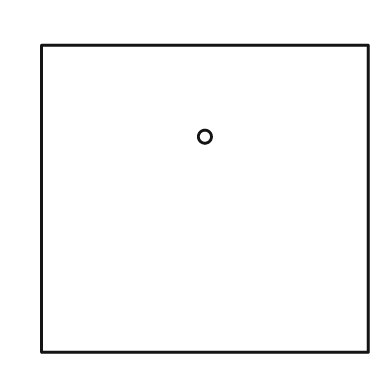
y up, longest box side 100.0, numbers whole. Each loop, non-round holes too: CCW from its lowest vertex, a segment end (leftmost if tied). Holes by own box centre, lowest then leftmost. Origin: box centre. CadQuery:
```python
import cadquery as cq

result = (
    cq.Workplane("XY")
    .moveTo(-50.0, -47.0)
    .lineTo(50.0, -47.0)
    .lineTo(50.0, 47.0)
    .lineTo(-50.0, 47.0)
    .close()
    .moveTo(0.0, 19.0)
    .circle(2.0)
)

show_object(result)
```